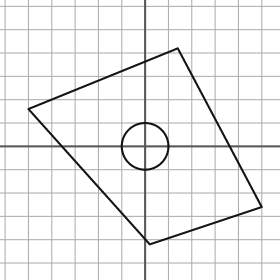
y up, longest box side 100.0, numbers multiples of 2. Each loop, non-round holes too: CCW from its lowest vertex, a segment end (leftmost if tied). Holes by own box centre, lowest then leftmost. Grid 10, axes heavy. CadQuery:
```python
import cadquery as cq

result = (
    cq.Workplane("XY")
    .moveTo(2.0, -42.0)
    .lineTo(50.0, -26.0)
    .lineTo(14.0, 42.0)
    .lineTo(-50.0, 16.0)
    .close()
    .moveTo(0.0, 0.0)
    .circle(10.0)
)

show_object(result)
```